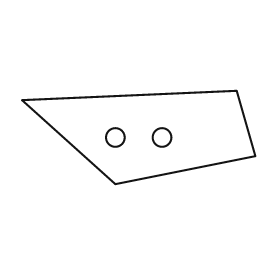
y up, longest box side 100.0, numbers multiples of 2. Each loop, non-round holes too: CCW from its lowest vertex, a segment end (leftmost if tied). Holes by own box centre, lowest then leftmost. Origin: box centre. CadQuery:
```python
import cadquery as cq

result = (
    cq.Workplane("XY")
    .moveTo(-10.0, -20.0)
    .lineTo(50.0, -8.0)
    .lineTo(42.0, 20.0)
    .lineTo(-50.0, 16.0)
    .close()
    .moveTo(-10.0, 0.0)
    .circle(4.0)
    .moveTo(10.0, 0.0)
    .circle(4.0)
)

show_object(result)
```